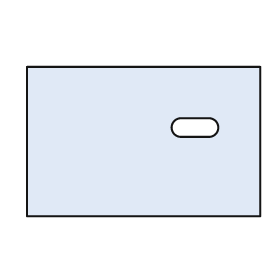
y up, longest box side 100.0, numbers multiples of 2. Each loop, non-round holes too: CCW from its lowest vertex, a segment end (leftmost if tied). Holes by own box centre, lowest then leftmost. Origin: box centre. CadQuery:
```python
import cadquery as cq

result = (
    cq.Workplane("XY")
    .moveTo(-50.0, -32.0)
    .lineTo(50.0, -32.0)
    .lineTo(50.0, 32.0)
    .lineTo(-50.0, 32.0)
    .close()
    .moveTo(16.0, 2.0)
    .lineTo(28.0, 2.0)
    .threePointArc((32.0, 6.0), (28.0, 10.0))
    .lineTo(16.0, 10.0)
    .threePointArc((12.0, 6.0), (16.0, 2.0))
    .close()
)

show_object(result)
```